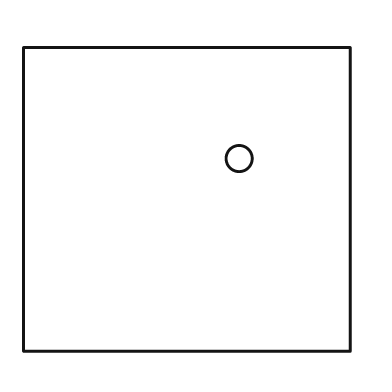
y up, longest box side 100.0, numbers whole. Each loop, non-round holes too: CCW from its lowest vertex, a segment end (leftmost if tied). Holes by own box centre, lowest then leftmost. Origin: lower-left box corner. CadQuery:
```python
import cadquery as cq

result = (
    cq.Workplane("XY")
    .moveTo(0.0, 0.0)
    .lineTo(100.0, 0.0)
    .lineTo(100.0, 93.0)
    .lineTo(0.0, 93.0)
    .close()
    .moveTo(66.0, 59.0)
    .circle(4.0)
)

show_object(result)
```